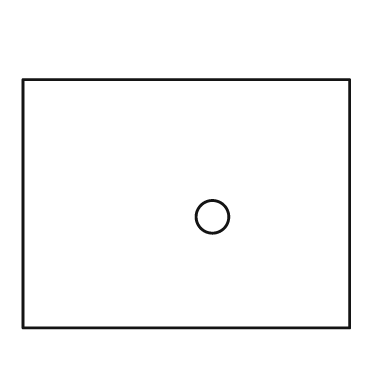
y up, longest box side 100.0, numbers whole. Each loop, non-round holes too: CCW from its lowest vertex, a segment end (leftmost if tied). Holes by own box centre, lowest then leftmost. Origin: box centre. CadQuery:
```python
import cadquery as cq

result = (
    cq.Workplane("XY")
    .moveTo(-50.0, -38.0)
    .lineTo(50.0, -38.0)
    .lineTo(50.0, 38.0)
    .lineTo(-50.0, 38.0)
    .close()
    .moveTo(8.0, -4.0)
    .circle(5.0)
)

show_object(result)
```